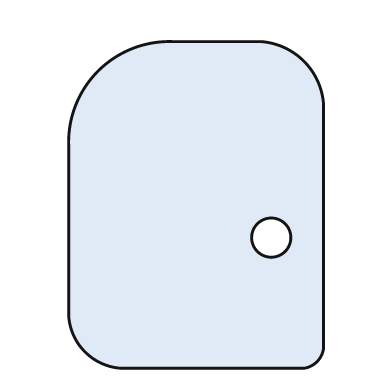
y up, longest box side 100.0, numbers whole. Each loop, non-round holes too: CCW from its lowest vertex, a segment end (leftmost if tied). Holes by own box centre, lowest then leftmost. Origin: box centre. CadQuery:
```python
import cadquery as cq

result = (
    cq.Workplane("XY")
    .moveTo(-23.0, -50.0)
    .lineTo(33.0, -50.0)
    .threePointArc((37.0, -48.0), (39.0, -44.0))
    .lineTo(39.0, 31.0)
    .threePointArc((33.0, 44.0), (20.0, 50.0))
    .lineTo(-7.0, 50.0)
    .threePointArc((-30.0, 41.0), (-39.0, 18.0))
    .lineTo(-39.0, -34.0)
    .threePointArc((-34.0, -45.0), (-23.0, -50.0))
    .close()
    .moveTo(23.0, -10.0)
    .circle(6.0)
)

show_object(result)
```